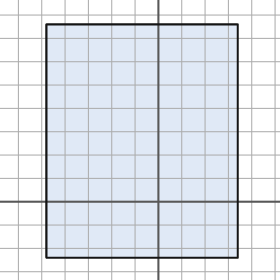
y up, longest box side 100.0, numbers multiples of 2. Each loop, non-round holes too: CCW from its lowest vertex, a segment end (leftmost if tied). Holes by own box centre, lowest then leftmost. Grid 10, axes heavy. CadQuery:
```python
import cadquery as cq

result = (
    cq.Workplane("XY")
    .moveTo(-48.0, -24.0)
    .lineTo(34.0, -24.0)
    .lineTo(34.0, 76.0)
    .lineTo(-48.0, 76.0)
    .close()
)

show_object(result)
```